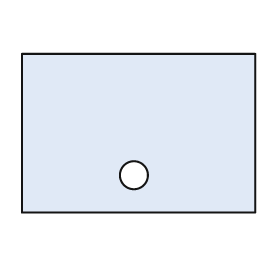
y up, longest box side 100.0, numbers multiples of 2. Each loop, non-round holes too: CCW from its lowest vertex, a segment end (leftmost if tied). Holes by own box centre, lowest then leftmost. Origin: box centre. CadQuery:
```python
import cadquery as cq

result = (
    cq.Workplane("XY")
    .moveTo(-50.0, -34.0)
    .lineTo(50.0, -34.0)
    .lineTo(50.0, 34.0)
    .lineTo(-50.0, 34.0)
    .close()
    .moveTo(-2.0, -18.0)
    .circle(6.0)
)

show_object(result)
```